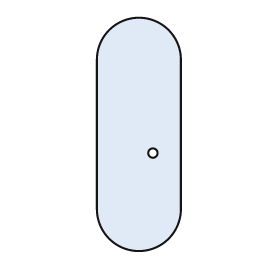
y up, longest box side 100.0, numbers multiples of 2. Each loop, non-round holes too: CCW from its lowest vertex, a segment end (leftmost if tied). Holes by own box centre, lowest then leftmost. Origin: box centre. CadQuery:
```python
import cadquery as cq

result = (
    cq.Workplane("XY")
    .moveTo(-18.0, -32.0)
    .threePointArc((0.0, -50.0), (18.0, -32.0))
    .lineTo(18.0, 32.0)
    .threePointArc((0.0, 50.0), (-18.0, 32.0))
    .close()
    .moveTo(6.0, -8.0)
    .circle(2.0)
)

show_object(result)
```